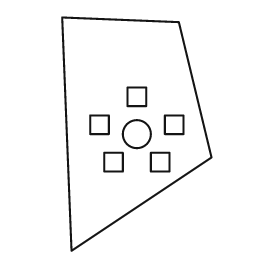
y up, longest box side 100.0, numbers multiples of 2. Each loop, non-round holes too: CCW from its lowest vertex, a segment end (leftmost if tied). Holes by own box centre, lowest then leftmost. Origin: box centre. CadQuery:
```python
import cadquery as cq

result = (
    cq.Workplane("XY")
    .moveTo(-28.0, -50.0)
    .lineTo(32.0, -10.0)
    .lineTo(18.0, 48.0)
    .lineTo(-32.0, 50.0)
    .close()
    .moveTo(-14.0, -16.0)
    .lineTo(-6.0, -16.0)
    .lineTo(-6.0, -8.0)
    .lineTo(-14.0, -8.0)
    .close()
    .moveTo(6.0, -16.0)
    .lineTo(14.0, -16.0)
    .lineTo(14.0, -8.0)
    .lineTo(6.0, -8.0)
    .close()
    .moveTo(0.0, 0.0)
    .circle(6.0)
    .moveTo(-20.0, 0.0)
    .lineTo(-12.0, 0.0)
    .lineTo(-12.0, 8.0)
    .lineTo(-20.0, 8.0)
    .close()
    .moveTo(12.0, 0.0)
    .lineTo(20.0, 0.0)
    .lineTo(20.0, 8.0)
    .lineTo(12.0, 8.0)
    .close()
    .moveTo(-4.0, 12.0)
    .lineTo(4.0, 12.0)
    .lineTo(4.0, 20.0)
    .lineTo(-4.0, 20.0)
    .close()
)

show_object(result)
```